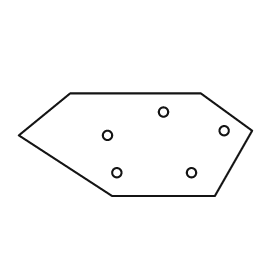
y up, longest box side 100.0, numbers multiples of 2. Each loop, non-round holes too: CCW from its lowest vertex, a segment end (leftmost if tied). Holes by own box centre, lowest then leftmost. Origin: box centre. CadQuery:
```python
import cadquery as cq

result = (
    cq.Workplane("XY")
    .moveTo(-10.0, -22.0)
    .lineTo(34.0, -22.0)
    .lineTo(50.0, 6.0)
    .lineTo(28.0, 22.0)
    .lineTo(-28.0, 22.0)
    .lineTo(-50.0, 4.0)
    .close()
    .moveTo(-8.0, -12.0)
    .circle(2.0)
    .moveTo(24.0, -12.0)
    .circle(2.0)
    .moveTo(-12.0, 4.0)
    .circle(2.0)
    .moveTo(38.0, 6.0)
    .circle(2.0)
    .moveTo(12.0, 14.0)
    .circle(2.0)
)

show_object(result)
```